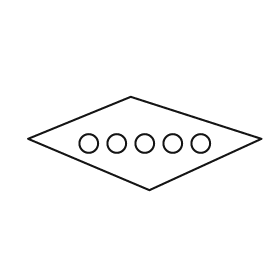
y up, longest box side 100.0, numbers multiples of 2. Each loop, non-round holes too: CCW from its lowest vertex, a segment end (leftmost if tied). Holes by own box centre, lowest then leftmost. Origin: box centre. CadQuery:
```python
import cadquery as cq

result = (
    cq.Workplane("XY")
    .moveTo(2.0, -20.0)
    .lineTo(50.0, 2.0)
    .lineTo(-6.0, 20.0)
    .lineTo(-50.0, 2.0)
    .close()
    .moveTo(-24.0, 0.0)
    .circle(4.0)
    .moveTo(-12.0, 0.0)
    .circle(4.0)
    .moveTo(0.0, 0.0)
    .circle(4.0)
    .moveTo(12.0, 0.0)
    .circle(4.0)
    .moveTo(24.0, 0.0)
    .circle(4.0)
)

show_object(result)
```